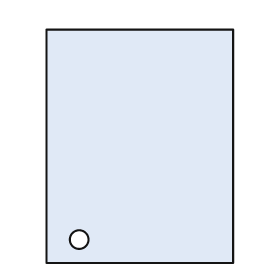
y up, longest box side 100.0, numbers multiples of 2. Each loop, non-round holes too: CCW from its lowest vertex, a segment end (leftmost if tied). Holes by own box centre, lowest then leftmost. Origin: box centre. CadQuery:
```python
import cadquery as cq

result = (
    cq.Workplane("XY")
    .moveTo(-40.0, -50.0)
    .lineTo(40.0, -50.0)
    .lineTo(40.0, 50.0)
    .lineTo(-40.0, 50.0)
    .close()
    .moveTo(-26.0, -40.0)
    .circle(4.0)
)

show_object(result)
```